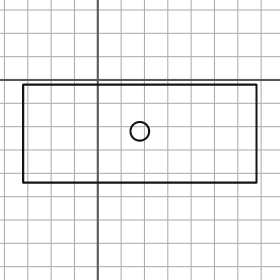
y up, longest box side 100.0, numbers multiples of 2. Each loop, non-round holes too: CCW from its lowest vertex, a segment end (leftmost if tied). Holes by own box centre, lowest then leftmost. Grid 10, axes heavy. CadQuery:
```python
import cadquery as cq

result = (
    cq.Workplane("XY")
    .moveTo(-32.0, -44.0)
    .lineTo(68.0, -44.0)
    .lineTo(68.0, -2.0)
    .lineTo(-32.0, -2.0)
    .close()
    .moveTo(18.0, -22.0)
    .circle(4.0)
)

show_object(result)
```